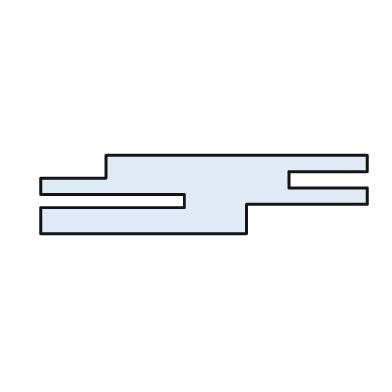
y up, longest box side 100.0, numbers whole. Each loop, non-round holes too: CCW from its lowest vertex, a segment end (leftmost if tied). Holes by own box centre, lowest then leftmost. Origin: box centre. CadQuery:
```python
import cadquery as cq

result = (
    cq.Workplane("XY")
    .moveTo(-50.0, -12.0)
    .lineTo(13.0, -12.0)
    .lineTo(13.0, -3.0)
    .lineTo(50.0, -3.0)
    .lineTo(50.0, 2.0)
    .lineTo(26.0, 2.0)
    .lineTo(26.0, 7.0)
    .lineTo(50.0, 7.0)
    .lineTo(50.0, 12.0)
    .lineTo(-30.0, 12.0)
    .lineTo(-30.0, 5.0)
    .lineTo(-50.0, 5.0)
    .lineTo(-50.0, 0.0)
    .lineTo(-6.0, 0.0)
    .lineTo(-6.0, -4.0)
    .lineTo(-50.0, -4.0)
    .close()
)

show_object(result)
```